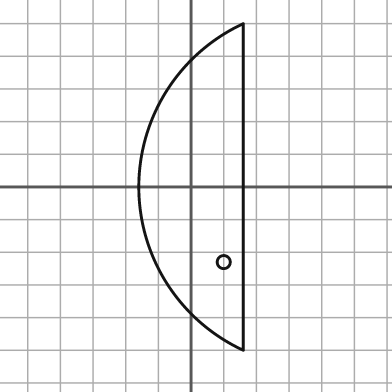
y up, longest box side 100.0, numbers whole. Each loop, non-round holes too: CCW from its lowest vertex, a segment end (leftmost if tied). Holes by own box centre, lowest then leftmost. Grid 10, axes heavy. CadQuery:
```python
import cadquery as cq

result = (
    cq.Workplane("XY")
    .moveTo(16.0, -50.0)
    .lineTo(16.0, 50.0)
    .threePointArc((-16.0, 0.0), (16.0, -50.0))
    .close()
    .moveTo(10.0, -23.0)
    .circle(2.0)
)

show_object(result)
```